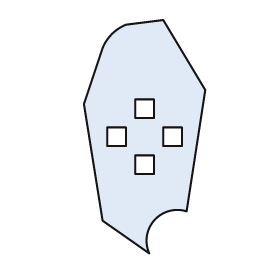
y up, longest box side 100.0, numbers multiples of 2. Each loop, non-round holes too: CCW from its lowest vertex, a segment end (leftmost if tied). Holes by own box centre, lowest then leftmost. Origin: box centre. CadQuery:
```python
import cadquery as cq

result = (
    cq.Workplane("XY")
    .moveTo(2.0, -50.0)
    .threePointArc((4.0, -36.0), (18.0, -32.0))
    .lineTo(26.0, 20.0)
    .lineTo(8.0, 50.0)
    .lineTo(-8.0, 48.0)
    .threePointArc((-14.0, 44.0), (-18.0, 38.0))
    .lineTo(-26.0, 14.0)
    .lineTo(-18.0, -36.0)
    .close()
    .moveTo(-4.0, -16.0)
    .lineTo(4.0, -16.0)
    .lineTo(4.0, -8.0)
    .lineTo(-4.0, -8.0)
    .close()
    .moveTo(-16.0, -4.0)
    .lineTo(-8.0, -4.0)
    .lineTo(-8.0, 4.0)
    .lineTo(-16.0, 4.0)
    .close()
    .moveTo(8.0, -4.0)
    .lineTo(16.0, -4.0)
    .lineTo(16.0, 4.0)
    .lineTo(8.0, 4.0)
    .close()
    .moveTo(-4.0, 8.0)
    .lineTo(4.0, 8.0)
    .lineTo(4.0, 16.0)
    .lineTo(-4.0, 16.0)
    .close()
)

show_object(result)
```